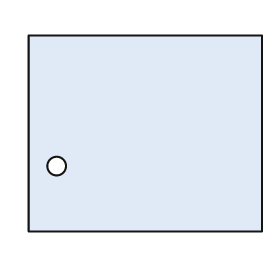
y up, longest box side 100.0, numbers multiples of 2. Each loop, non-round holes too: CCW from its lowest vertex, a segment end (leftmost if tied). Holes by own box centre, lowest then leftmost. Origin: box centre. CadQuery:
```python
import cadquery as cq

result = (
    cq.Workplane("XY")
    .moveTo(-50.0, -42.0)
    .lineTo(50.0, -42.0)
    .lineTo(50.0, 42.0)
    .lineTo(-50.0, 42.0)
    .close()
    .moveTo(-38.0, -14.0)
    .circle(4.0)
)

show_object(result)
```